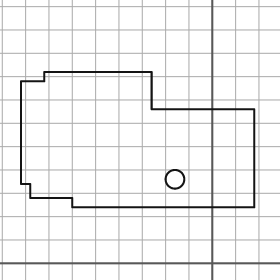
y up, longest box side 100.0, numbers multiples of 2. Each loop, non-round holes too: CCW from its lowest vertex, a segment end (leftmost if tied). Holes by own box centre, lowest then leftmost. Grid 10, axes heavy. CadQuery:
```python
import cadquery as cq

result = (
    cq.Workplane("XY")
    .moveTo(-60.0, 24.0)
    .lineTo(18.0, 24.0)
    .lineTo(18.0, 66.0)
    .lineTo(-26.0, 66.0)
    .lineTo(-26.0, 82.0)
    .lineTo(-72.0, 82.0)
    .lineTo(-72.0, 78.0)
    .lineTo(-82.0, 78.0)
    .lineTo(-82.0, 34.0)
    .lineTo(-78.0, 34.0)
    .lineTo(-78.0, 28.0)
    .lineTo(-60.0, 28.0)
    .close()
    .moveTo(-16.0, 36.0)
    .circle(4.0)
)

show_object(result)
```